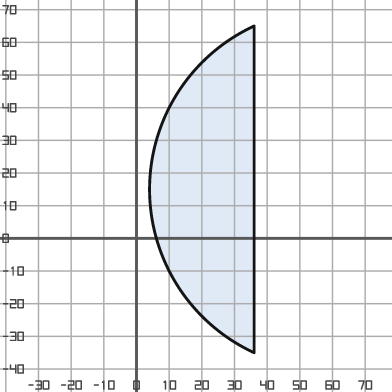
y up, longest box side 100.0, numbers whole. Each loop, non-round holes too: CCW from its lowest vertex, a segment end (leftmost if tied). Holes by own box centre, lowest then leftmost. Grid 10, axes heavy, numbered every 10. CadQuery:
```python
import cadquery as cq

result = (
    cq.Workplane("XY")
    .moveTo(36.0, -35.0)
    .lineTo(36.0, 65.0)
    .threePointArc((4.0, 15.0), (36.0, -35.0))
    .close()
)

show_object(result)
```